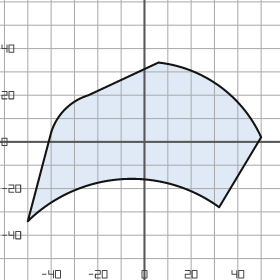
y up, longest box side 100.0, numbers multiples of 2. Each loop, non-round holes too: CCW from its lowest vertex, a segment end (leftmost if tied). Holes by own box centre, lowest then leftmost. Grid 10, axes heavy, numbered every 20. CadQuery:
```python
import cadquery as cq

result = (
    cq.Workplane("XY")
    .moveTo(-50.0, -34.0)
    .threePointArc((-10.0, -16.0), (32.0, -28.0))
    .lineTo(50.0, 2.0)
    .threePointArc((32.0, 24.0), (6.0, 34.0))
    .lineTo(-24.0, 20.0)
    .threePointArc((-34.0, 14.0), (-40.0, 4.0))
    .close()
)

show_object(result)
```